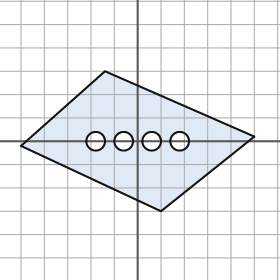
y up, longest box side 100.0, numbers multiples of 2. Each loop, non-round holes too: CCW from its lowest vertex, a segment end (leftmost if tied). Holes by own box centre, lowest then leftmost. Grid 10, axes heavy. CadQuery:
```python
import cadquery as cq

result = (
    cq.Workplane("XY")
    .moveTo(10.0, -30.0)
    .lineTo(50.0, 2.0)
    .lineTo(-14.0, 30.0)
    .lineTo(-50.0, -2.0)
    .close()
    .moveTo(-18.0, 0.0)
    .circle(4.0)
    .moveTo(-6.0, 0.0)
    .circle(4.0)
    .moveTo(6.0, 0.0)
    .circle(4.0)
    .moveTo(18.0, 0.0)
    .circle(4.0)
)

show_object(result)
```